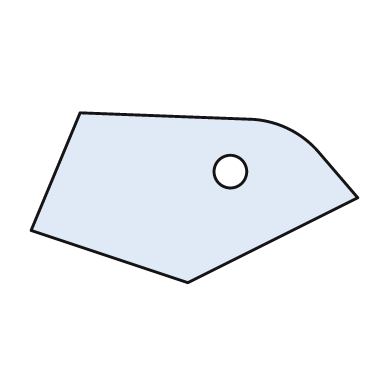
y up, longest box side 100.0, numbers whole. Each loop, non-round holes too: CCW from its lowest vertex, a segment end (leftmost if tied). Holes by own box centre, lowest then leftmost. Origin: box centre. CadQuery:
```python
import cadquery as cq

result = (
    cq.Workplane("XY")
    .moveTo(-2.0, -26.0)
    .lineTo(50.0, 0.0)
    .lineTo(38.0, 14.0)
    .threePointArc((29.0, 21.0), (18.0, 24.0))
    .lineTo(-35.0, 26.0)
    .lineTo(-50.0, -10.0)
    .close()
    .moveTo(11.0, 8.0)
    .circle(5.0)
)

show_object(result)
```